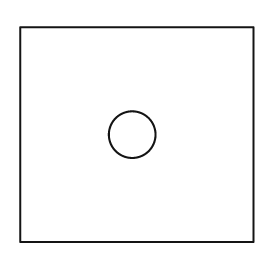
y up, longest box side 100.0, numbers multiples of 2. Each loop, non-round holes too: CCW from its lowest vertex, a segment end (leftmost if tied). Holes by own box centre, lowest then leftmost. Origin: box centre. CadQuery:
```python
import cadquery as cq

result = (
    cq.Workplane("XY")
    .moveTo(-50.0, -46.0)
    .lineTo(50.0, -46.0)
    .lineTo(50.0, 46.0)
    .lineTo(-50.0, 46.0)
    .close()
    .moveTo(-2.0, 0.0)
    .circle(10.0)
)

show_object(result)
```